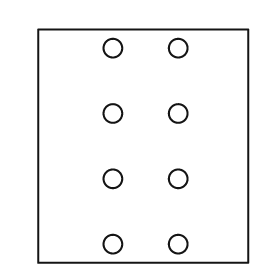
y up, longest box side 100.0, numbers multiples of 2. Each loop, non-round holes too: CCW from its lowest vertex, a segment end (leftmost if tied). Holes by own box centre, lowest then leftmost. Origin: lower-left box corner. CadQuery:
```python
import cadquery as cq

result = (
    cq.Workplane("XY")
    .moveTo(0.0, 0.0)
    .lineTo(90.0, 0.0)
    .lineTo(90.0, 100.0)
    .lineTo(0.0, 100.0)
    .close()
    .moveTo(32.0, 8.0)
    .circle(4.0)
    .moveTo(60.0, 8.0)
    .circle(4.0)
    .moveTo(32.0, 36.0)
    .circle(4.0)
    .moveTo(60.0, 36.0)
    .circle(4.0)
    .moveTo(32.0, 64.0)
    .circle(4.0)
    .moveTo(60.0, 64.0)
    .circle(4.0)
    .moveTo(32.0, 92.0)
    .circle(4.0)
    .moveTo(60.0, 92.0)
    .circle(4.0)
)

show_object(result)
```